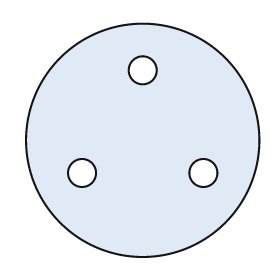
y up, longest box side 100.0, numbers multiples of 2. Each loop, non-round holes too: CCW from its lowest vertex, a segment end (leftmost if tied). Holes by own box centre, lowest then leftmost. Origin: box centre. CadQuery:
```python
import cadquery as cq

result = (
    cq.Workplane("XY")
    .moveTo(0.0, 0.0)
    .circle(50.0)
    .moveTo(-26.0, -14.0)
    .circle(6.0)
    .moveTo(26.0, -14.0)
    .circle(6.0)
    .moveTo(0.0, 30.0)
    .circle(6.0)
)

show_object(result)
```